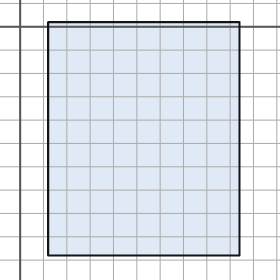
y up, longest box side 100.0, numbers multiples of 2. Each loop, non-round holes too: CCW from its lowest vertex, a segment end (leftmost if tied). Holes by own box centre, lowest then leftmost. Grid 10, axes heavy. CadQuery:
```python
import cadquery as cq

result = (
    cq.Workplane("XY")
    .moveTo(12.0, -98.0)
    .lineTo(94.0, -98.0)
    .lineTo(94.0, 2.0)
    .lineTo(12.0, 2.0)
    .close()
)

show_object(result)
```